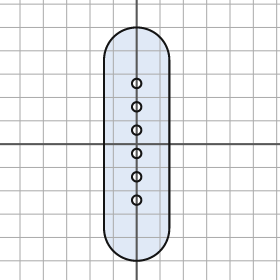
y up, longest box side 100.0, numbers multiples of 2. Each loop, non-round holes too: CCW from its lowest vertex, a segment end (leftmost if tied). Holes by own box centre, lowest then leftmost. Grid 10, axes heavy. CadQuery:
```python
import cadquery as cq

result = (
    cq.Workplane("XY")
    .moveTo(-14.0, -36.0)
    .threePointArc((0.0, -50.0), (14.0, -36.0))
    .lineTo(14.0, 36.0)
    .threePointArc((0.0, 50.0), (-14.0, 36.0))
    .close()
    .moveTo(0.0, -24.0)
    .circle(2.0)
    .moveTo(0.0, -14.0)
    .circle(2.0)
    .moveTo(0.0, -4.0)
    .circle(2.0)
    .moveTo(0.0, 6.0)
    .circle(2.0)
    .moveTo(0.0, 16.0)
    .circle(2.0)
    .moveTo(0.0, 26.0)
    .circle(2.0)
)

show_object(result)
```